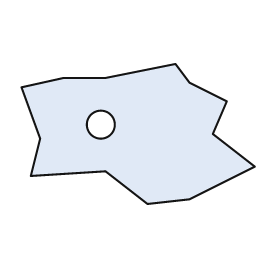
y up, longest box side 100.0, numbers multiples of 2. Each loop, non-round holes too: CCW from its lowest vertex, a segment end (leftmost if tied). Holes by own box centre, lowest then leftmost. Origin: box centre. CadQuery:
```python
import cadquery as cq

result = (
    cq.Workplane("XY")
    .moveTo(4.0, -30.0)
    .lineTo(22.0, -28.0)
    .lineTo(50.0, -14.0)
    .lineTo(32.0, 0.0)
    .lineTo(38.0, 14.0)
    .lineTo(22.0, 22.0)
    .lineTo(16.0, 30.0)
    .lineTo(-14.0, 24.0)
    .lineTo(-32.0, 24.0)
    .lineTo(-50.0, 20.0)
    .lineTo(-42.0, -2.0)
    .lineTo(-46.0, -18.0)
    .lineTo(-14.0, -16.0)
    .close()
    .moveTo(-16.0, 4.0)
    .circle(6.0)
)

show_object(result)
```